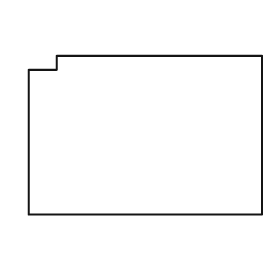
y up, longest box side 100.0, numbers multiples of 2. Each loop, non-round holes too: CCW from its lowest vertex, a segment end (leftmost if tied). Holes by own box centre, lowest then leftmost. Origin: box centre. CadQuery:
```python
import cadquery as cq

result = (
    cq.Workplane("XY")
    .moveTo(-50.0, -34.0)
    .lineTo(50.0, -34.0)
    .lineTo(50.0, 34.0)
    .lineTo(-38.0, 34.0)
    .lineTo(-38.0, 28.0)
    .lineTo(-50.0, 28.0)
    .close()
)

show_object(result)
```